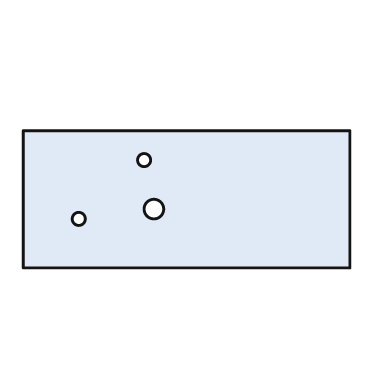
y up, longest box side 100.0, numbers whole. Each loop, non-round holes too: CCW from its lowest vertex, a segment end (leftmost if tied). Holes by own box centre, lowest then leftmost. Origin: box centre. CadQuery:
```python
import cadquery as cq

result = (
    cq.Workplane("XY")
    .moveTo(-50.0, -21.0)
    .lineTo(50.0, -21.0)
    .lineTo(50.0, 21.0)
    .lineTo(-50.0, 21.0)
    .close()
    .moveTo(-33.0, -6.0)
    .circle(2.0)
    .moveTo(-10.0, -3.0)
    .circle(3.0)
    .moveTo(-13.0, 12.0)
    .circle(2.0)
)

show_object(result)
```